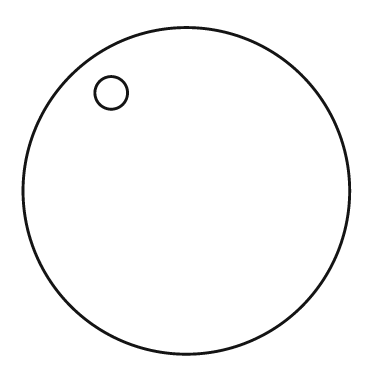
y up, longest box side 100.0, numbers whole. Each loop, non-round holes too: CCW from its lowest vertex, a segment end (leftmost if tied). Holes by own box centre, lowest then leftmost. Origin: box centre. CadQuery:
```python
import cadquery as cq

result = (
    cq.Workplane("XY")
    .moveTo(0.0, 0.0)
    .circle(50.0)
    .moveTo(-23.0, 30.0)
    .circle(5.0)
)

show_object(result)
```